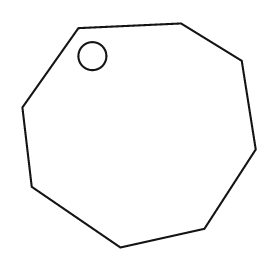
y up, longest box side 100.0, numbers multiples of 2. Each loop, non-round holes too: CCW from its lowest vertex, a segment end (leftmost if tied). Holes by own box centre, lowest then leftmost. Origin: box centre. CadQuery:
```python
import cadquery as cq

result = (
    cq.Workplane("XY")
    .moveTo(-8.0, -48.0)
    .lineTo(28.0, -40.0)
    .lineTo(50.0, -6.0)
    .lineTo(44.0, 32.0)
    .lineTo(18.0, 48.0)
    .lineTo(-26.0, 46.0)
    .lineTo(-50.0, 12.0)
    .lineTo(-46.0, -22.0)
    .close()
    .moveTo(-20.0, 34.0)
    .circle(6.0)
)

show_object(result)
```